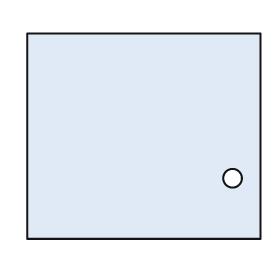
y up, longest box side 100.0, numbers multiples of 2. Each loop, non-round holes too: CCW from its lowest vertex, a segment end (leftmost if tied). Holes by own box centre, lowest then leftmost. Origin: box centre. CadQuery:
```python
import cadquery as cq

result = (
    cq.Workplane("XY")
    .moveTo(-50.0, -44.0)
    .lineTo(50.0, -44.0)
    .lineTo(50.0, 44.0)
    .lineTo(-50.0, 44.0)
    .close()
    .moveTo(38.0, -18.0)
    .circle(4.0)
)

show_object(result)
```